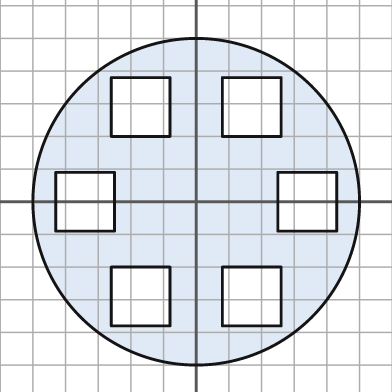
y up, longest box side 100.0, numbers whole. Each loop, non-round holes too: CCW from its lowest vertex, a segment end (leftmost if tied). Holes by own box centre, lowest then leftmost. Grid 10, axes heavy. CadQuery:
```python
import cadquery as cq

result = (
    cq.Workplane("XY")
    .moveTo(0.0, 0.0)
    .circle(50.0)
    .moveTo(-26.0, -38.0)
    .lineTo(-8.0, -38.0)
    .lineTo(-8.0, -20.0)
    .lineTo(-26.0, -20.0)
    .close()
    .moveTo(8.0, -38.0)
    .lineTo(26.0, -38.0)
    .lineTo(26.0, -20.0)
    .lineTo(8.0, -20.0)
    .close()
    .moveTo(-43.0, -9.0)
    .lineTo(-25.0, -9.0)
    .lineTo(-25.0, 9.0)
    .lineTo(-43.0, 9.0)
    .close()
    .moveTo(25.0, -9.0)
    .lineTo(43.0, -9.0)
    .lineTo(43.0, 9.0)
    .lineTo(25.0, 9.0)
    .close()
    .moveTo(-26.0, 20.0)
    .lineTo(-8.0, 20.0)
    .lineTo(-8.0, 38.0)
    .lineTo(-26.0, 38.0)
    .close()
    .moveTo(8.0, 20.0)
    .lineTo(26.0, 20.0)
    .lineTo(26.0, 38.0)
    .lineTo(8.0, 38.0)
    .close()
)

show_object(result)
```